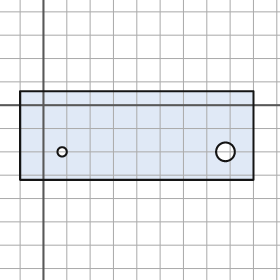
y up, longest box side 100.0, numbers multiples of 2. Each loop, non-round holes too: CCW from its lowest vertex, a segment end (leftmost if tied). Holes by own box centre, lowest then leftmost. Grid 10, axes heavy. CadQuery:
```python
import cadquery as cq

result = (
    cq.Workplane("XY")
    .moveTo(-10.0, -32.0)
    .lineTo(90.0, -32.0)
    .lineTo(90.0, 6.0)
    .lineTo(-10.0, 6.0)
    .close()
    .moveTo(8.0, -20.0)
    .circle(2.0)
    .moveTo(78.0, -20.0)
    .circle(4.0)
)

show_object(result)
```